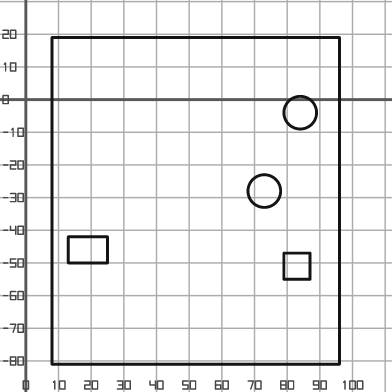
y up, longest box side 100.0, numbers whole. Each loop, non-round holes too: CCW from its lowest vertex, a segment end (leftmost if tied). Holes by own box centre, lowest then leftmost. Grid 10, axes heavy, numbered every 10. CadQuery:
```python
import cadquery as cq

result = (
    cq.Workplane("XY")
    .moveTo(8.0, -81.0)
    .lineTo(96.0, -81.0)
    .lineTo(96.0, 19.0)
    .lineTo(8.0, 19.0)
    .close()
    .moveTo(79.0, -55.0)
    .lineTo(87.0, -55.0)
    .lineTo(87.0, -47.0)
    .lineTo(79.0, -47.0)
    .close()
    .moveTo(13.0, -50.0)
    .lineTo(25.0, -50.0)
    .lineTo(25.0, -42.0)
    .lineTo(13.0, -42.0)
    .close()
    .moveTo(73.0, -28.0)
    .circle(5.0)
    .moveTo(84.0, -4.0)
    .circle(5.0)
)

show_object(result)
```